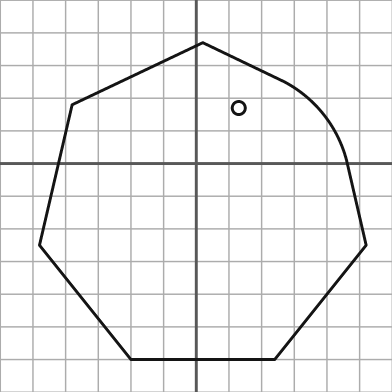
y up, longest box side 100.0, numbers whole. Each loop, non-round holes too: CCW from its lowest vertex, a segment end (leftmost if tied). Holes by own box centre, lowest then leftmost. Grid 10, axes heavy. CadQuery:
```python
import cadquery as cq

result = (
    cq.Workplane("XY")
    .moveTo(-20.0, -60.0)
    .lineTo(24.0, -60.0)
    .lineTo(52.0, -25.0)
    .lineTo(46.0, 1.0)
    .threePointArc((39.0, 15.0), (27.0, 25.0))
    .lineTo(2.0, 37.0)
    .lineTo(-38.0, 18.0)
    .lineTo(-48.0, -25.0)
    .close()
    .moveTo(13.0, 17.0)
    .circle(2.0)
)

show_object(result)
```